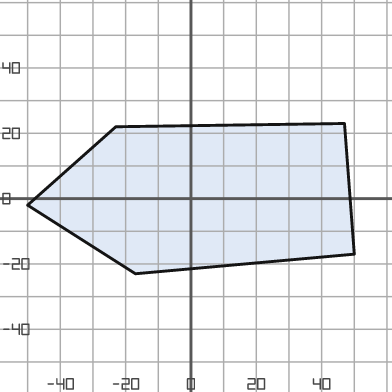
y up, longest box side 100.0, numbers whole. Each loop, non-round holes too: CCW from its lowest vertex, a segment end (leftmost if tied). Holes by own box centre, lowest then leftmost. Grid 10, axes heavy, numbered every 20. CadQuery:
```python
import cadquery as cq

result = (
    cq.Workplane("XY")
    .moveTo(-17.0, -23.0)
    .lineTo(50.0, -17.0)
    .lineTo(47.0, 23.0)
    .lineTo(-23.0, 22.0)
    .lineTo(-50.0, -2.0)
    .close()
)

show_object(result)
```